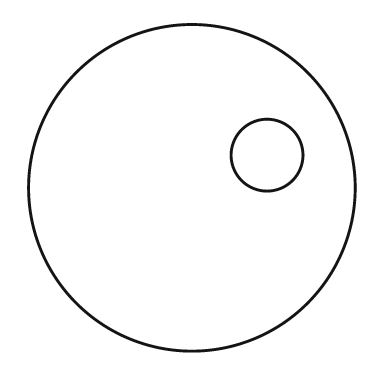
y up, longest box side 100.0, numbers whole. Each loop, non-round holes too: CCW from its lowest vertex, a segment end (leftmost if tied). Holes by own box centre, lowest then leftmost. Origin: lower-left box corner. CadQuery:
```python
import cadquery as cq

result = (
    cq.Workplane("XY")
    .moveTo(50.0, 50.0)
    .circle(50.0)
    .moveTo(73.0, 60.0)
    .circle(11.0)
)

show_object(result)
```